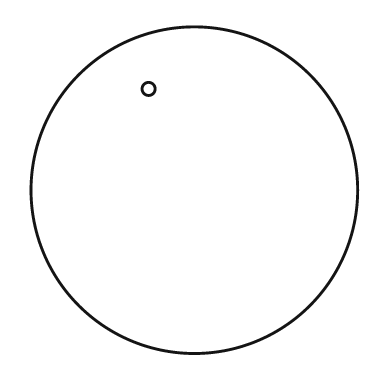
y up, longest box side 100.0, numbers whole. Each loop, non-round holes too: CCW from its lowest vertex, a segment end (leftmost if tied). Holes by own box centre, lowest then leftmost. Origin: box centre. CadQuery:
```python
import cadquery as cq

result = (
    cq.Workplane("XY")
    .moveTo(0.0, 0.0)
    .circle(50.0)
    .moveTo(-14.0, 31.0)
    .circle(2.0)
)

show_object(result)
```